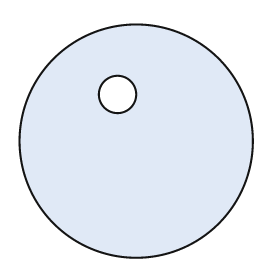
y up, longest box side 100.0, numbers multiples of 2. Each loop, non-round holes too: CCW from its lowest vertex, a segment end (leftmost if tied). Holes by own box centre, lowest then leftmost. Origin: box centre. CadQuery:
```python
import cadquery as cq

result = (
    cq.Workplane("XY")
    .moveTo(0.0, 0.0)
    .circle(50.0)
    .moveTo(-8.0, 20.0)
    .circle(8.0)
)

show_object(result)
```